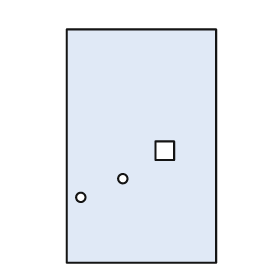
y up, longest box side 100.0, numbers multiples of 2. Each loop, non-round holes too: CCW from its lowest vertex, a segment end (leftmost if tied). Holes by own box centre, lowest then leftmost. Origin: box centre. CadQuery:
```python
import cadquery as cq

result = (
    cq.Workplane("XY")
    .moveTo(-32.0, -50.0)
    .lineTo(32.0, -50.0)
    .lineTo(32.0, 50.0)
    .lineTo(-32.0, 50.0)
    .close()
    .moveTo(-26.0, -22.0)
    .circle(2.0)
    .moveTo(-8.0, -14.0)
    .circle(2.0)
    .moveTo(6.0, -6.0)
    .lineTo(14.0, -6.0)
    .lineTo(14.0, 2.0)
    .lineTo(6.0, 2.0)
    .close()
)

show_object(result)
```